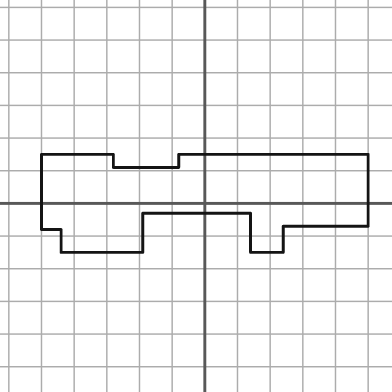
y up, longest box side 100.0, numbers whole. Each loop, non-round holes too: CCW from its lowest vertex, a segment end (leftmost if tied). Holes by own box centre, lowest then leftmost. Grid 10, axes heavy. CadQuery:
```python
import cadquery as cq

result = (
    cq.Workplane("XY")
    .moveTo(-44.0, -15.0)
    .lineTo(-19.0, -15.0)
    .lineTo(-19.0, -3.0)
    .lineTo(14.0, -3.0)
    .lineTo(14.0, -15.0)
    .lineTo(24.0, -15.0)
    .lineTo(24.0, -7.0)
    .lineTo(50.0, -7.0)
    .lineTo(50.0, 15.0)
    .lineTo(-8.0, 15.0)
    .lineTo(-8.0, 11.0)
    .lineTo(-28.0, 11.0)
    .lineTo(-28.0, 15.0)
    .lineTo(-50.0, 15.0)
    .lineTo(-50.0, -8.0)
    .lineTo(-44.0, -8.0)
    .close()
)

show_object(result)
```